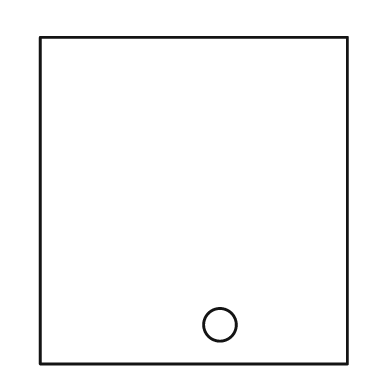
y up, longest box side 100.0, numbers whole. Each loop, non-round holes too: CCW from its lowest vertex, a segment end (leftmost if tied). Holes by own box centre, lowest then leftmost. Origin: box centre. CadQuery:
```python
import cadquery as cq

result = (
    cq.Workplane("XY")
    .moveTo(-47.0, -50.0)
    .lineTo(47.0, -50.0)
    .lineTo(47.0, 50.0)
    .lineTo(-47.0, 50.0)
    .close()
    .moveTo(8.0, -38.0)
    .circle(5.0)
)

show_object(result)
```